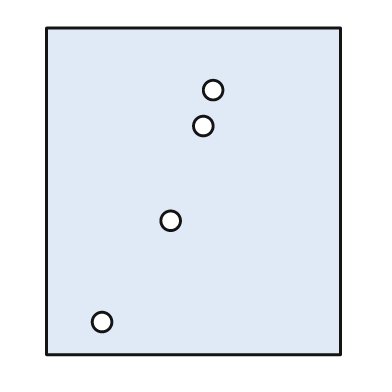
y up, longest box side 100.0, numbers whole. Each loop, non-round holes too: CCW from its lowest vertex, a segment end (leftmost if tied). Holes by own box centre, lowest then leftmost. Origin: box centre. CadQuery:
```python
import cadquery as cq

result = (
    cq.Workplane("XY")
    .moveTo(-45.0, -50.0)
    .lineTo(45.0, -50.0)
    .lineTo(45.0, 50.0)
    .lineTo(-45.0, 50.0)
    .close()
    .moveTo(-28.0, -40.0)
    .circle(3.0)
    .moveTo(-7.0, -9.0)
    .circle(3.0)
    .moveTo(3.0, 20.0)
    .circle(3.0)
    .moveTo(6.0, 31.0)
    .circle(3.0)
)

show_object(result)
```